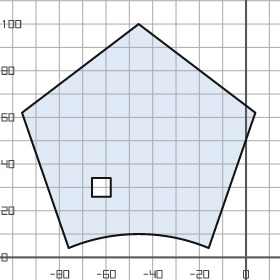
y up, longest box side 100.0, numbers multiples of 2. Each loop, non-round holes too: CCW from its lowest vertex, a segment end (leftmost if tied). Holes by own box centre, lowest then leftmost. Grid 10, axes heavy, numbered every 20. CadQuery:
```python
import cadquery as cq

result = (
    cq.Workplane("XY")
    .moveTo(-76.0, 4.0)
    .threePointArc((-46.0, 10.0), (-16.0, 4.0))
    .lineTo(4.0, 62.0)
    .lineTo(-46.0, 100.0)
    .lineTo(-96.0, 62.0)
    .close()
    .moveTo(-66.0, 26.0)
    .lineTo(-58.0, 26.0)
    .lineTo(-58.0, 34.0)
    .lineTo(-66.0, 34.0)
    .close()
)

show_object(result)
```